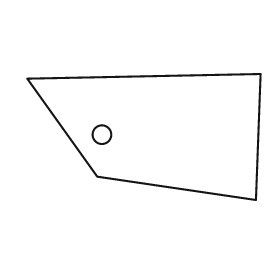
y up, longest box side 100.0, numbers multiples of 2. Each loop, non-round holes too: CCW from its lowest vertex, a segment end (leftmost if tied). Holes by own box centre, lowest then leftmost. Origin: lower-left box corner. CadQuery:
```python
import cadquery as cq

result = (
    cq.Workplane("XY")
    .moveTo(98.0, 0.0)
    .lineTo(100.0, 54.0)
    .lineTo(0.0, 52.0)
    .lineTo(30.0, 10.0)
    .close()
    .moveTo(32.0, 28.0)
    .circle(4.0)
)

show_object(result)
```